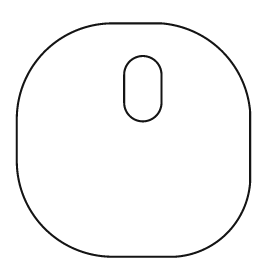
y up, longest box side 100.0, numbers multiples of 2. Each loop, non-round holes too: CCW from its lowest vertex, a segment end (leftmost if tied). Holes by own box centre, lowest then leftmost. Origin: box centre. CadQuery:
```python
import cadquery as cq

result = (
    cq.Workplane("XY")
    .moveTo(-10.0, -50.0)
    .lineTo(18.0, -50.0)
    .threePointArc((40.0, -40.0), (50.0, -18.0))
    .lineTo(50.0, 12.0)
    .threePointArc((38.0, 38.0), (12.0, 50.0))
    .lineTo(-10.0, 50.0)
    .threePointArc((-38.0, 38.0), (-50.0, 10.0))
    .lineTo(-50.0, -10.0)
    .threePointArc((-38.0, -38.0), (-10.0, -50.0))
    .close()
    .moveTo(-4.0, 16.0)
    .threePointArc((4.0, 8.0), (12.0, 16.0))
    .lineTo(12.0, 28.0)
    .threePointArc((4.0, 36.0), (-4.0, 28.0))
    .close()
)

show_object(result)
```